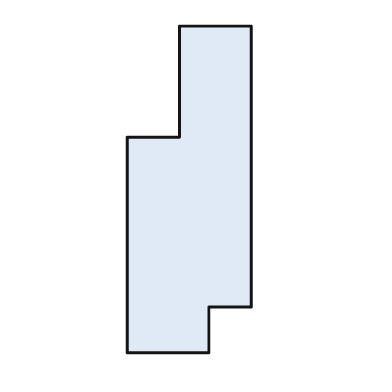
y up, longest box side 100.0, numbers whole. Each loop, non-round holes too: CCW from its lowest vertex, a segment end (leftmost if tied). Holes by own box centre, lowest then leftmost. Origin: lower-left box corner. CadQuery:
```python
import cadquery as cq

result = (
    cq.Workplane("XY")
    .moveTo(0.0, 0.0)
    .lineTo(25.0, 0.0)
    .lineTo(25.0, 14.0)
    .lineTo(38.0, 14.0)
    .lineTo(38.0, 100.0)
    .lineTo(16.0, 100.0)
    .lineTo(16.0, 66.0)
    .lineTo(0.0, 66.0)
    .close()
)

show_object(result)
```